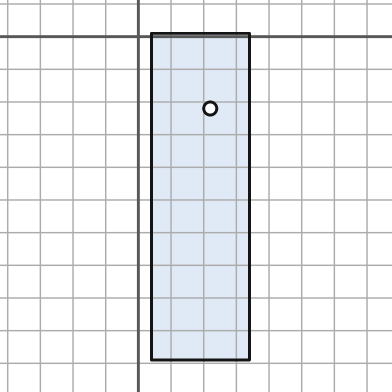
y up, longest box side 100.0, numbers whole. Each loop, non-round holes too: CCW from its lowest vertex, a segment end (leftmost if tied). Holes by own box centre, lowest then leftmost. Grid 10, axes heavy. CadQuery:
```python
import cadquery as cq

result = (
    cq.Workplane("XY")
    .moveTo(4.0, -99.0)
    .lineTo(34.0, -99.0)
    .lineTo(34.0, 1.0)
    .lineTo(4.0, 1.0)
    .close()
    .moveTo(22.0, -22.0)
    .circle(2.0)
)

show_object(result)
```